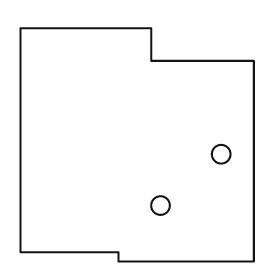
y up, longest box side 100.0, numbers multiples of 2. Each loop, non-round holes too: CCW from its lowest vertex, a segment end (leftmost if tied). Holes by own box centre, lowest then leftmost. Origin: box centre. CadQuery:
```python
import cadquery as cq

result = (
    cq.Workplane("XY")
    .moveTo(-8.0, -50.0)
    .lineTo(50.0, -50.0)
    .lineTo(50.0, 36.0)
    .lineTo(6.0, 36.0)
    .lineTo(6.0, 50.0)
    .lineTo(-50.0, 50.0)
    .lineTo(-50.0, -46.0)
    .lineTo(-8.0, -46.0)
    .close()
    .moveTo(10.0, -26.0)
    .circle(4.0)
    .moveTo(36.0, -4.0)
    .circle(4.0)
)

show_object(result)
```